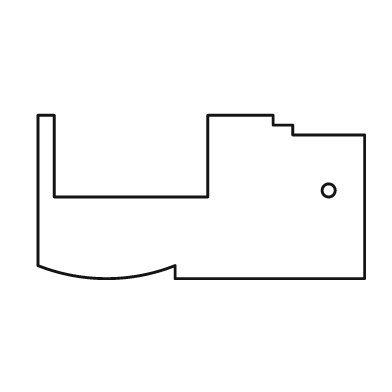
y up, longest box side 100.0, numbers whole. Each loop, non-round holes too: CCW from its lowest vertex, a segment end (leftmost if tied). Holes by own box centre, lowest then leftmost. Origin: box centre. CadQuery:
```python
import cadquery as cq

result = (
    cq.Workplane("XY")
    .moveTo(-8.0, -25.0)
    .lineTo(50.0, -25.0)
    .lineTo(50.0, 19.0)
    .lineTo(28.0, 19.0)
    .lineTo(28.0, 22.0)
    .lineTo(22.0, 22.0)
    .lineTo(22.0, 25.0)
    .lineTo(2.0, 25.0)
    .lineTo(2.0, 0.0)
    .lineTo(-45.0, 0.0)
    .lineTo(-45.0, 25.0)
    .lineTo(-50.0, 25.0)
    .lineTo(-50.0, -21.0)
    .threePointArc((-29.0, -25.0), (-8.0, -21.0))
    .close()
    .moveTo(39.0, 2.0)
    .circle(2.0)
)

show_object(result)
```